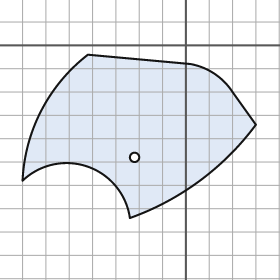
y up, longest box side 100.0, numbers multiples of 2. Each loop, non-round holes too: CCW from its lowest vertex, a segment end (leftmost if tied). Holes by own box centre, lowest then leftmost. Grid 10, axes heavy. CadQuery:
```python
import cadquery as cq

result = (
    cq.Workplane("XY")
    .moveTo(-24.0, -74.0)
    .threePointArc((6.0, -58.0), (30.0, -34.0))
    .lineTo(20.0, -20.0)
    .threePointArc((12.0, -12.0), (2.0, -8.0))
    .lineTo(-42.0, -4.0)
    .threePointArc((-62.0, -28.0), (-70.0, -58.0))
    .threePointArc((-42.0, -52.0), (-24.0, -74.0))
    .close()
    .moveTo(-22.0, -48.0)
    .circle(2.0)
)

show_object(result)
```